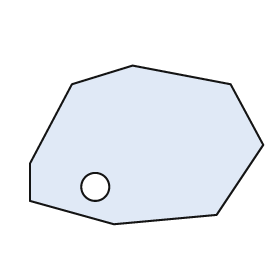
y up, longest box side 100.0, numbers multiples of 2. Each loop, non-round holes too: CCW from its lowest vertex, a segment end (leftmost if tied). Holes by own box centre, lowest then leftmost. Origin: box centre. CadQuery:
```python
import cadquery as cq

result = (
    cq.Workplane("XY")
    .moveTo(-14.0, -34.0)
    .lineTo(30.0, -30.0)
    .lineTo(50.0, 0.0)
    .lineTo(36.0, 26.0)
    .lineTo(-6.0, 34.0)
    .lineTo(-32.0, 26.0)
    .lineTo(-50.0, -8.0)
    .lineTo(-50.0, -24.0)
    .close()
    .moveTo(-22.0, -18.0)
    .circle(6.0)
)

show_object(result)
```